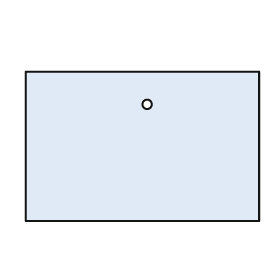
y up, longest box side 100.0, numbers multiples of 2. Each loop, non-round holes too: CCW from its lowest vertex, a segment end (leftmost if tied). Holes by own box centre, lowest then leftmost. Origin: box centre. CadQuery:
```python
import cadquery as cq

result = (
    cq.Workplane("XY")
    .moveTo(-50.0, -32.0)
    .lineTo(50.0, -32.0)
    .lineTo(50.0, 32.0)
    .lineTo(-50.0, 32.0)
    .close()
    .moveTo(2.0, 18.0)
    .circle(2.0)
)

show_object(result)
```